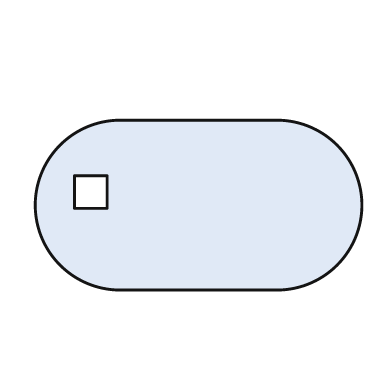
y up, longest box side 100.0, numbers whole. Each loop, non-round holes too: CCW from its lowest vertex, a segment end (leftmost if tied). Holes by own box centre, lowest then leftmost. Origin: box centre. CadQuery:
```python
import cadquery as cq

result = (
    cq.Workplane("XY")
    .moveTo(-24.0, -26.0)
    .lineTo(24.0, -26.0)
    .threePointArc((50.0, 0.0), (24.0, 26.0))
    .lineTo(-24.0, 26.0)
    .threePointArc((-50.0, 0.0), (-24.0, -26.0))
    .close()
    .moveTo(-38.0, -1.0)
    .lineTo(-28.0, -1.0)
    .lineTo(-28.0, 9.0)
    .lineTo(-38.0, 9.0)
    .close()
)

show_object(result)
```